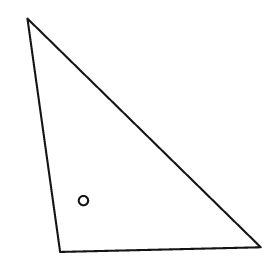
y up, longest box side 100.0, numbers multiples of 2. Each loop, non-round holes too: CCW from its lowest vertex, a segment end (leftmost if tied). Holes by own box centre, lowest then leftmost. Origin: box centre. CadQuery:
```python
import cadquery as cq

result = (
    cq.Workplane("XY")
    .moveTo(-36.0, -50.0)
    .lineTo(50.0, -48.0)
    .lineTo(-50.0, 50.0)
    .close()
    .moveTo(-26.0, -28.0)
    .circle(2.0)
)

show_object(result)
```